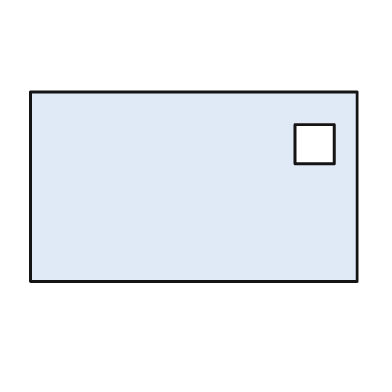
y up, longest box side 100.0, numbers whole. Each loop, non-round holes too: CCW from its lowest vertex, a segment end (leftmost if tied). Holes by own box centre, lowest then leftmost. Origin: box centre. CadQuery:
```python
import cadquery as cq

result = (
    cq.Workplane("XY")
    .moveTo(-50.0, -29.0)
    .lineTo(50.0, -29.0)
    .lineTo(50.0, 29.0)
    .lineTo(-50.0, 29.0)
    .close()
    .moveTo(31.0, 7.0)
    .lineTo(43.0, 7.0)
    .lineTo(43.0, 19.0)
    .lineTo(31.0, 19.0)
    .close()
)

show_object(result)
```